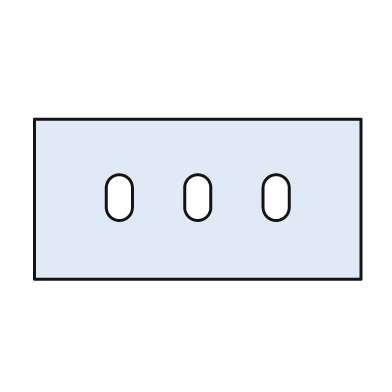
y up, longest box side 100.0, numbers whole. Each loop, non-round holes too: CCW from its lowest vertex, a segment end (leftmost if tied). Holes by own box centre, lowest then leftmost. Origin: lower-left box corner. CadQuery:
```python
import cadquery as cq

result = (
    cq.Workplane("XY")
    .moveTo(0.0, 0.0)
    .lineTo(100.0, 0.0)
    .lineTo(100.0, 49.0)
    .lineTo(0.0, 49.0)
    .close()
    .moveTo(22.0, 22.0)
    .threePointArc((26.0, 18.0), (30.0, 22.0))
    .lineTo(30.0, 28.0)
    .threePointArc((26.0, 32.0), (22.0, 28.0))
    .close()
    .moveTo(46.0, 22.0)
    .threePointArc((50.0, 18.0), (54.0, 22.0))
    .lineTo(54.0, 28.0)
    .threePointArc((50.0, 32.0), (46.0, 28.0))
    .close()
    .moveTo(70.0, 22.0)
    .threePointArc((74.0, 18.0), (78.0, 22.0))
    .lineTo(78.0, 28.0)
    .threePointArc((74.0, 32.0), (70.0, 28.0))
    .close()
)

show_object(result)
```